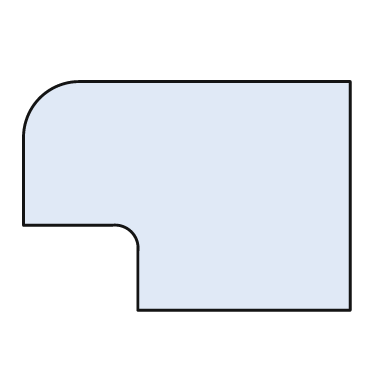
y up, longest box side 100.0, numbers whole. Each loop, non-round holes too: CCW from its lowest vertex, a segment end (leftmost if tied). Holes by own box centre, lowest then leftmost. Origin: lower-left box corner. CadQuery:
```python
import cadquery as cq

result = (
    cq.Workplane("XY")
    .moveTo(35.0, 0.0)
    .lineTo(100.0, 0.0)
    .lineTo(100.0, 70.0)
    .lineTo(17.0, 70.0)
    .threePointArc((5.0, 65.0), (0.0, 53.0))
    .lineTo(0.0, 26.0)
    .lineTo(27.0, 26.0)
    .threePointArc((33.0, 24.0), (35.0, 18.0))
    .close()
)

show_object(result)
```